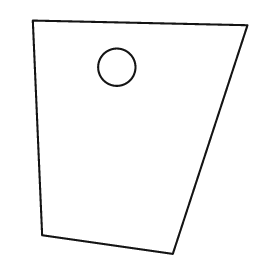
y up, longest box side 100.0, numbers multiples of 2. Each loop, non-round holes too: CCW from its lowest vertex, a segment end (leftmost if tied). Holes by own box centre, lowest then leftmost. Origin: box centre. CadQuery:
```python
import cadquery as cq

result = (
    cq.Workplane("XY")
    .moveTo(14.0, -50.0)
    .lineTo(46.0, 48.0)
    .lineTo(-46.0, 50.0)
    .lineTo(-42.0, -42.0)
    .close()
    .moveTo(-10.0, 30.0)
    .circle(8.0)
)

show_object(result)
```